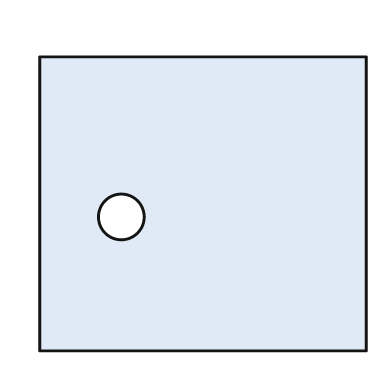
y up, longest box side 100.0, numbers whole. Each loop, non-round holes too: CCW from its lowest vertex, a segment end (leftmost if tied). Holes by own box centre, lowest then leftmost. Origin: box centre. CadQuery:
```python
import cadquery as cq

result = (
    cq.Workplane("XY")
    .moveTo(-50.0, -45.0)
    .lineTo(50.0, -45.0)
    .lineTo(50.0, 45.0)
    .lineTo(-50.0, 45.0)
    .close()
    .moveTo(-25.0, -4.0)
    .circle(7.0)
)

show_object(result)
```